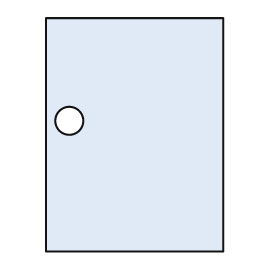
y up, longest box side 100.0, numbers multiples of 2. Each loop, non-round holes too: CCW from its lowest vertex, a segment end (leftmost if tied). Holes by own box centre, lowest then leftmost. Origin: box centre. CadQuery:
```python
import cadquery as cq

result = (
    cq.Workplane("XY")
    .moveTo(-38.0, -50.0)
    .lineTo(38.0, -50.0)
    .lineTo(38.0, 50.0)
    .lineTo(-38.0, 50.0)
    .close()
    .moveTo(-28.0, 6.0)
    .circle(6.0)
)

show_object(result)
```